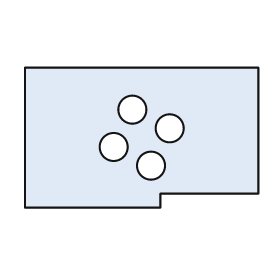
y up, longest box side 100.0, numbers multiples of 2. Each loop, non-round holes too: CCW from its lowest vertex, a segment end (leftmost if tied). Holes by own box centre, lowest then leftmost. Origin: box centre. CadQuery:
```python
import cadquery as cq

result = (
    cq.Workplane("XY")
    .moveTo(-50.0, -30.0)
    .lineTo(8.0, -30.0)
    .lineTo(8.0, -24.0)
    .lineTo(50.0, -24.0)
    .lineTo(50.0, 30.0)
    .lineTo(-50.0, 30.0)
    .close()
    .moveTo(4.0, -12.0)
    .circle(6.0)
    .moveTo(-12.0, -4.0)
    .circle(6.0)
    .moveTo(12.0, 4.0)
    .circle(6.0)
    .moveTo(-4.0, 12.0)
    .circle(6.0)
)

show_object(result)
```